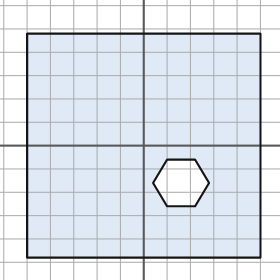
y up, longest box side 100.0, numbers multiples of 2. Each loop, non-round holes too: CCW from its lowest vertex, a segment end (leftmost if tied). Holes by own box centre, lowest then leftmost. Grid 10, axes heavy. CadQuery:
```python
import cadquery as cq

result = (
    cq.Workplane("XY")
    .moveTo(-50.0, -48.0)
    .lineTo(50.0, -48.0)
    .lineTo(50.0, 48.0)
    .lineTo(-50.0, 48.0)
    .close()
    .moveTo(10.0, -26.0)
    .lineTo(22.0, -26.0)
    .lineTo(28.0, -16.0)
    .lineTo(22.0, -6.0)
    .lineTo(10.0, -6.0)
    .lineTo(4.0, -16.0)
    .close()
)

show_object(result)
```